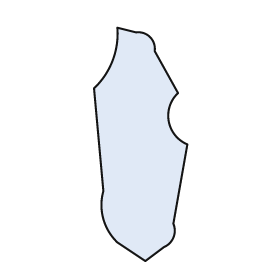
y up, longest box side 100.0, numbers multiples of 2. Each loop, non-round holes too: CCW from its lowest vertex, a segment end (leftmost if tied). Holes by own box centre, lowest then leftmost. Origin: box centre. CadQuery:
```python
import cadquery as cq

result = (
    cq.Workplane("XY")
    .moveTo(2.0, -50.0)
    .lineTo(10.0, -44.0)
    .threePointArc((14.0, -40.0), (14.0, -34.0))
    .lineTo(20.0, 0.0)
    .threePointArc((12.0, 10.0), (16.0, 22.0))
    .lineTo(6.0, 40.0)
    .threePointArc((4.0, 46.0), (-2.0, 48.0))
    .lineTo(-10.0, 50.0)
    .threePointArc((-12.0, 36.0), (-20.0, 24.0))
    .lineTo(-16.0, -20.0)
    .threePointArc((-16.0, -32.0), (-10.0, -42.0))
    .close()
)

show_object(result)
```